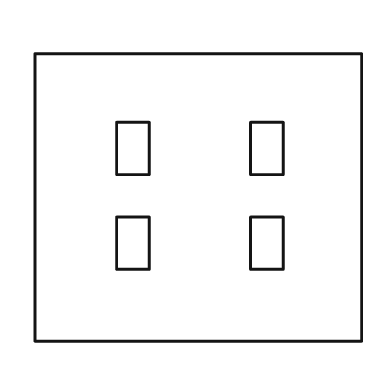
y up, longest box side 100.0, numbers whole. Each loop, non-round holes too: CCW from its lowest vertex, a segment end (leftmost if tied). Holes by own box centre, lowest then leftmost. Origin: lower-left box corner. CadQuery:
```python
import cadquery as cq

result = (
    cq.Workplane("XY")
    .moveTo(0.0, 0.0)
    .lineTo(100.0, 0.0)
    .lineTo(100.0, 88.0)
    .lineTo(0.0, 88.0)
    .close()
    .moveTo(25.0, 22.0)
    .lineTo(35.0, 22.0)
    .lineTo(35.0, 38.0)
    .lineTo(25.0, 38.0)
    .close()
    .moveTo(66.0, 22.0)
    .lineTo(76.0, 22.0)
    .lineTo(76.0, 38.0)
    .lineTo(66.0, 38.0)
    .close()
    .moveTo(25.0, 51.0)
    .lineTo(35.0, 51.0)
    .lineTo(35.0, 67.0)
    .lineTo(25.0, 67.0)
    .close()
    .moveTo(66.0, 51.0)
    .lineTo(76.0, 51.0)
    .lineTo(76.0, 67.0)
    .lineTo(66.0, 67.0)
    .close()
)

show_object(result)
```